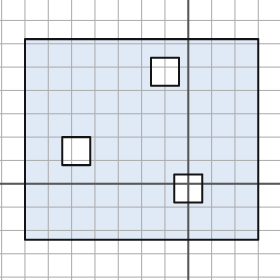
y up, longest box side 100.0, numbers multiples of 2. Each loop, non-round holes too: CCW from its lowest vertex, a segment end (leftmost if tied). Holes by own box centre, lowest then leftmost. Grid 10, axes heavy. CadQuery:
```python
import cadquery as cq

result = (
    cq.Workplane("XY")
    .moveTo(-70.0, -24.0)
    .lineTo(30.0, -24.0)
    .lineTo(30.0, 62.0)
    .lineTo(-70.0, 62.0)
    .close()
    .moveTo(-6.0, -8.0)
    .lineTo(6.0, -8.0)
    .lineTo(6.0, 4.0)
    .lineTo(-6.0, 4.0)
    .close()
    .moveTo(-54.0, 8.0)
    .lineTo(-42.0, 8.0)
    .lineTo(-42.0, 20.0)
    .lineTo(-54.0, 20.0)
    .close()
    .moveTo(-16.0, 42.0)
    .lineTo(-4.0, 42.0)
    .lineTo(-4.0, 54.0)
    .lineTo(-16.0, 54.0)
    .close()
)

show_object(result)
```